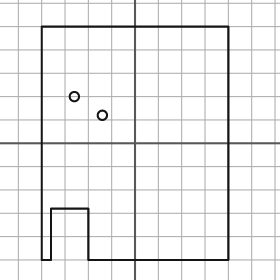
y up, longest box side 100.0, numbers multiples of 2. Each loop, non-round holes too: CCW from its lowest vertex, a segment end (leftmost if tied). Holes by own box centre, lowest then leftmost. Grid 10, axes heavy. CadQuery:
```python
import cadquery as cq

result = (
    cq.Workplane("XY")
    .moveTo(-40.0, -50.0)
    .lineTo(-36.0, -50.0)
    .lineTo(-36.0, -28.0)
    .lineTo(-20.0, -28.0)
    .lineTo(-20.0, -50.0)
    .lineTo(40.0, -50.0)
    .lineTo(40.0, 50.0)
    .lineTo(-40.0, 50.0)
    .close()
    .moveTo(-14.0, 12.0)
    .circle(2.0)
    .moveTo(-26.0, 20.0)
    .circle(2.0)
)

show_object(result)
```